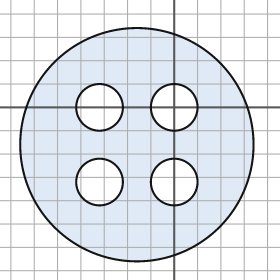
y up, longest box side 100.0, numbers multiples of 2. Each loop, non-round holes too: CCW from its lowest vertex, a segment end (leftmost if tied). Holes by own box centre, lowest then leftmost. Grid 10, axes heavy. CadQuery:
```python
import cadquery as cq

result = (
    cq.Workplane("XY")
    .moveTo(-16.0, -16.0)
    .circle(50.0)
    .moveTo(-32.0, -32.0)
    .circle(10.0)
    .moveTo(0.0, -32.0)
    .circle(10.0)
    .moveTo(-32.0, 0.0)
    .circle(10.0)
    .moveTo(0.0, 0.0)
    .circle(10.0)
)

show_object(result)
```